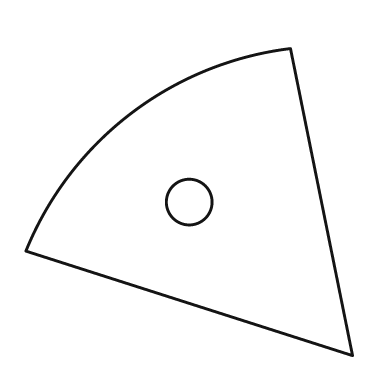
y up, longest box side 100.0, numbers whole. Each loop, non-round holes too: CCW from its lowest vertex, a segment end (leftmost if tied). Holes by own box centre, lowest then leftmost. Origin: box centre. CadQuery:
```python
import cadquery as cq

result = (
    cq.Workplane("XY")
    .moveTo(50.0, -47.0)
    .lineTo(31.0, 47.0)
    .threePointArc((-18.0, 27.0), (-50.0, -15.0))
    .close()
    .moveTo(0.0, 0.0)
    .circle(7.0)
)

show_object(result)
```